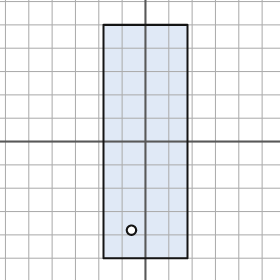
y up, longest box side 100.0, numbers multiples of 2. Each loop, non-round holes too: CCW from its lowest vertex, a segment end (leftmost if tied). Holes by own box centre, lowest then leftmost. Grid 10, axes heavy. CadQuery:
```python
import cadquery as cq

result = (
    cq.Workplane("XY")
    .moveTo(-18.0, -50.0)
    .lineTo(18.0, -50.0)
    .lineTo(18.0, 50.0)
    .lineTo(-18.0, 50.0)
    .close()
    .moveTo(-6.0, -38.0)
    .circle(2.0)
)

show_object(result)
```